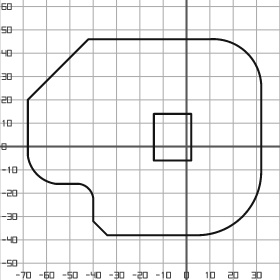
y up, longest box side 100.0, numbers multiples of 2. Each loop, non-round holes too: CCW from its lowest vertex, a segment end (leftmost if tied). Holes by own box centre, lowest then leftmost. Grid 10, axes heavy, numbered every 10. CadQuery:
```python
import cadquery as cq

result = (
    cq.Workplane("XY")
    .moveTo(-34.0, -38.0)
    .lineTo(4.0, -38.0)
    .threePointArc((24.0, -30.0), (32.0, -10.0))
    .lineTo(32.0, 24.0)
    .threePointArc((26.0, 40.0), (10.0, 46.0))
    .lineTo(-42.0, 46.0)
    .lineTo(-68.0, 20.0)
    .lineTo(-68.0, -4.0)
    .threePointArc((-64.0, -12.0), (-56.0, -16.0))
    .lineTo(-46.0, -16.0)
    .threePointArc((-42.0, -18.0), (-40.0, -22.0))
    .lineTo(-40.0, -32.0)
    .close()
    .moveTo(-14.0, -6.0)
    .lineTo(2.0, -6.0)
    .lineTo(2.0, 14.0)
    .lineTo(-14.0, 14.0)
    .close()
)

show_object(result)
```